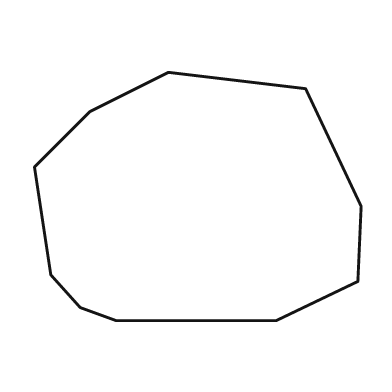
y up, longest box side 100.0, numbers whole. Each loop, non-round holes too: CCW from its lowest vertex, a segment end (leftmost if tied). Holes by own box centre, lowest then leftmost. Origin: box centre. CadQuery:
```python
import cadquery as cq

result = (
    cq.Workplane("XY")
    .moveTo(-25.0, -38.0)
    .lineTo(24.0, -38.0)
    .lineTo(49.0, -26.0)
    .lineTo(50.0, -3.0)
    .lineTo(33.0, 33.0)
    .lineTo(-9.0, 38.0)
    .lineTo(-33.0, 26.0)
    .lineTo(-50.0, 9.0)
    .lineTo(-45.0, -24.0)
    .lineTo(-36.0, -34.0)
    .close()
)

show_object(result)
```